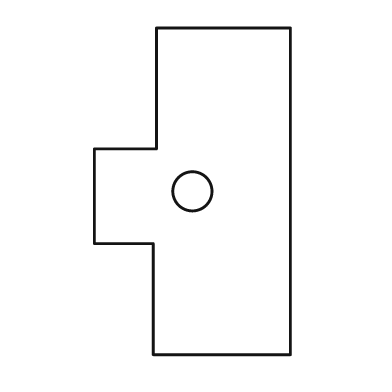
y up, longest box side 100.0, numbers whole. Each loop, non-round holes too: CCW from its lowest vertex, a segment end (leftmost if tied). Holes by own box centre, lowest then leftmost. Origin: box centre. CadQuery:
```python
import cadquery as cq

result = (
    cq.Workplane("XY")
    .moveTo(-12.0, -50.0)
    .lineTo(30.0, -50.0)
    .lineTo(30.0, 50.0)
    .lineTo(-11.0, 50.0)
    .lineTo(-11.0, 13.0)
    .lineTo(-30.0, 13.0)
    .lineTo(-30.0, -16.0)
    .lineTo(-12.0, -16.0)
    .close()
    .moveTo(0.0, 0.0)
    .circle(6.0)
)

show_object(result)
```